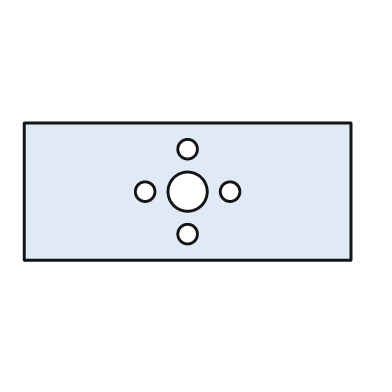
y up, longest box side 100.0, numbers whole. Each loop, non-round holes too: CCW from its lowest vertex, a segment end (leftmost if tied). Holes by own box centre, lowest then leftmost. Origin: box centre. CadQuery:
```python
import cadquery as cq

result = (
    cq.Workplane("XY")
    .moveTo(-50.0, -21.0)
    .lineTo(50.0, -21.0)
    .lineTo(50.0, 21.0)
    .lineTo(-50.0, 21.0)
    .close()
    .moveTo(0.0, -13.0)
    .circle(3.0)
    .moveTo(-13.0, 0.0)
    .circle(3.0)
    .moveTo(0.0, 0.0)
    .circle(6.0)
    .moveTo(13.0, 0.0)
    .circle(3.0)
    .moveTo(0.0, 13.0)
    .circle(3.0)
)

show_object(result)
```